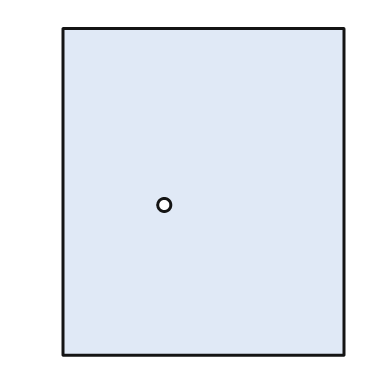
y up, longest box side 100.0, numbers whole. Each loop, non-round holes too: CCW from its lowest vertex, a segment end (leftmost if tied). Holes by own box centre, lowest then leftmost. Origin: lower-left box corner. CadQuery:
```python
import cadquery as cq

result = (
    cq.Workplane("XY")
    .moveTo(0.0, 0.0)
    .lineTo(86.0, 0.0)
    .lineTo(86.0, 100.0)
    .lineTo(0.0, 100.0)
    .close()
    .moveTo(31.0, 46.0)
    .circle(2.0)
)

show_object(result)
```